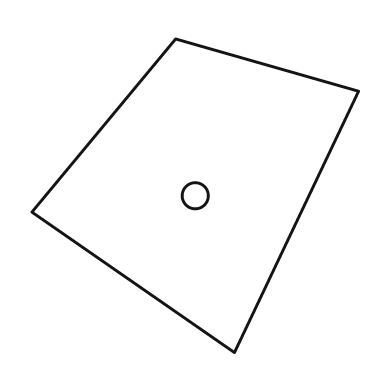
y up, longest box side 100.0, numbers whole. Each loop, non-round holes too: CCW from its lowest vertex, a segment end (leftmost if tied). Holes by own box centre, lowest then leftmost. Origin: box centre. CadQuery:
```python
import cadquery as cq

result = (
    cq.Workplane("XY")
    .moveTo(12.0, -48.0)
    .lineTo(50.0, 32.0)
    .lineTo(-6.0, 48.0)
    .lineTo(-50.0, -5.0)
    .close()
    .moveTo(0.0, 0.0)
    .circle(4.0)
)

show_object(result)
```